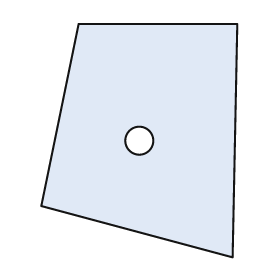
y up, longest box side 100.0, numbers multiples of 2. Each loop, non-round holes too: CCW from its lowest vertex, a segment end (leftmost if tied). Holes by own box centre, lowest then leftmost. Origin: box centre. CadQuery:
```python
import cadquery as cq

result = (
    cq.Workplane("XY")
    .moveTo(40.0, -50.0)
    .lineTo(42.0, 50.0)
    .lineTo(-26.0, 50.0)
    .lineTo(-42.0, -28.0)
    .close()
    .moveTo(0.0, 0.0)
    .circle(6.0)
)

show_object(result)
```